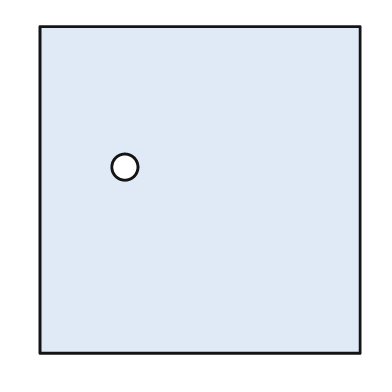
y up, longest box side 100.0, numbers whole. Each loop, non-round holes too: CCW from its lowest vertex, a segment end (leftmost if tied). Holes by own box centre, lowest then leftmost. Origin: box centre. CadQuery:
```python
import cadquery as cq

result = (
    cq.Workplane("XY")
    .moveTo(-49.0, -50.0)
    .lineTo(49.0, -50.0)
    .lineTo(49.0, 50.0)
    .lineTo(-49.0, 50.0)
    .close()
    .moveTo(-23.0, 7.0)
    .circle(4.0)
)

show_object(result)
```